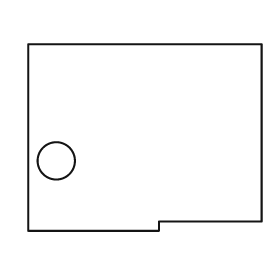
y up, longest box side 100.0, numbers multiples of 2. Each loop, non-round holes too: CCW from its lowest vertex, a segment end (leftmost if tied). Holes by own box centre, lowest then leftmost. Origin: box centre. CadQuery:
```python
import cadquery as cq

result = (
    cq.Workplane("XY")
    .moveTo(-50.0, -40.0)
    .lineTo(6.0, -40.0)
    .lineTo(6.0, -36.0)
    .lineTo(50.0, -36.0)
    .lineTo(50.0, 40.0)
    .lineTo(-50.0, 40.0)
    .close()
    .moveTo(-38.0, -10.0)
    .circle(8.0)
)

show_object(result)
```